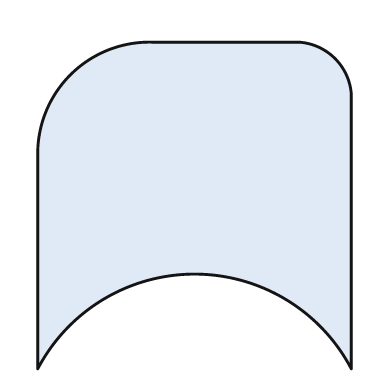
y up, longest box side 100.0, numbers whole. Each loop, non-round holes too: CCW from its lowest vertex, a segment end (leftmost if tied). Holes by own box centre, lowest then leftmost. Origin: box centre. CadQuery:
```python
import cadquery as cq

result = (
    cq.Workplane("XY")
    .moveTo(-48.0, -50.0)
    .threePointArc((0.0, -21.0), (48.0, -50.0))
    .lineTo(48.0, 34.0)
    .threePointArc((43.0, 45.0), (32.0, 50.0))
    .lineTo(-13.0, 50.0)
    .threePointArc((-38.0, 40.0), (-48.0, 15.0))
    .close()
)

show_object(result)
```